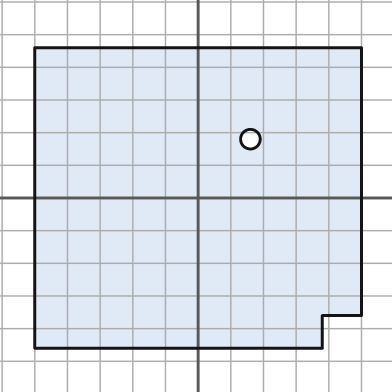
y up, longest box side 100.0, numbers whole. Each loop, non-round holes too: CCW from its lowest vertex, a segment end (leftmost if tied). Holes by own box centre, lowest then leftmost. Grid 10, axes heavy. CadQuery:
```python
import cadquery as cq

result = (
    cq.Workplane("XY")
    .moveTo(-50.0, -46.0)
    .lineTo(38.0, -46.0)
    .lineTo(38.0, -36.0)
    .lineTo(50.0, -36.0)
    .lineTo(50.0, 46.0)
    .lineTo(-50.0, 46.0)
    .close()
    .moveTo(16.0, 18.0)
    .circle(3.0)
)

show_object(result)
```